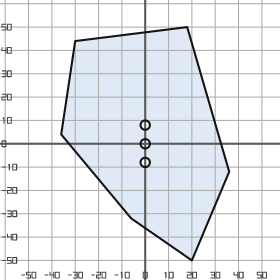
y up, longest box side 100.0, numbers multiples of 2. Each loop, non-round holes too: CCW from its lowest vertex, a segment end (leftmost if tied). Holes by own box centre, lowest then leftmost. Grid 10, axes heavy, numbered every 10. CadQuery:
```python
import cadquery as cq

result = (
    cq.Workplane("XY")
    .moveTo(20.0, -50.0)
    .lineTo(36.0, -12.0)
    .lineTo(18.0, 50.0)
    .lineTo(-30.0, 44.0)
    .lineTo(-36.0, 4.0)
    .lineTo(-6.0, -32.0)
    .close()
    .moveTo(0.0, -8.0)
    .circle(2.0)
    .moveTo(0.0, 0.0)
    .circle(2.0)
    .moveTo(0.0, 8.0)
    .circle(2.0)
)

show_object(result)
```